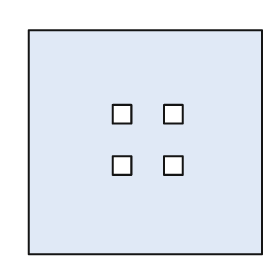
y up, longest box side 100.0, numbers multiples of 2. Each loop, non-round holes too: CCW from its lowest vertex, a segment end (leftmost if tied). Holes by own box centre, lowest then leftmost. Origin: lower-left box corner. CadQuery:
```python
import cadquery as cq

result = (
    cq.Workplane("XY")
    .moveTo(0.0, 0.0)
    .lineTo(100.0, 0.0)
    .lineTo(100.0, 96.0)
    .lineTo(0.0, 96.0)
    .close()
    .moveTo(36.0, 34.0)
    .lineTo(44.0, 34.0)
    .lineTo(44.0, 42.0)
    .lineTo(36.0, 42.0)
    .close()
    .moveTo(58.0, 34.0)
    .lineTo(66.0, 34.0)
    .lineTo(66.0, 42.0)
    .lineTo(58.0, 42.0)
    .close()
    .moveTo(36.0, 56.0)
    .lineTo(44.0, 56.0)
    .lineTo(44.0, 64.0)
    .lineTo(36.0, 64.0)
    .close()
    .moveTo(58.0, 56.0)
    .lineTo(66.0, 56.0)
    .lineTo(66.0, 64.0)
    .lineTo(58.0, 64.0)
    .close()
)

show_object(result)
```